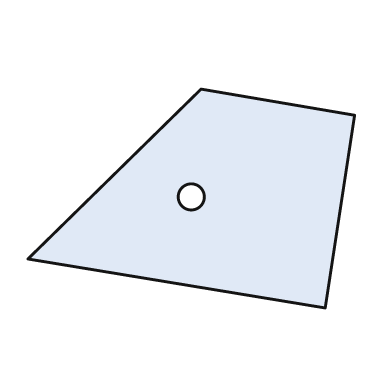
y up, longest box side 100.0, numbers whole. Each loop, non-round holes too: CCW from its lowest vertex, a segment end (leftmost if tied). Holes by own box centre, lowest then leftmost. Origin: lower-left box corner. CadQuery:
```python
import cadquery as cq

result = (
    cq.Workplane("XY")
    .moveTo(91.0, 0.0)
    .lineTo(100.0, 59.0)
    .lineTo(53.0, 67.0)
    .lineTo(0.0, 15.0)
    .close()
    .moveTo(50.0, 34.0)
    .circle(4.0)
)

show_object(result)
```